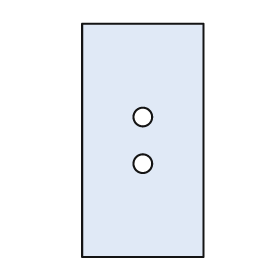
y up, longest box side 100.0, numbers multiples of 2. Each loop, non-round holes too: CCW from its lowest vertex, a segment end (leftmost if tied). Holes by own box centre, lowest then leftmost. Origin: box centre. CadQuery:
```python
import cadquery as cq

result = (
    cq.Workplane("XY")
    .moveTo(-26.0, -50.0)
    .lineTo(26.0, -50.0)
    .lineTo(26.0, 50.0)
    .lineTo(-26.0, 50.0)
    .close()
    .moveTo(0.0, -10.0)
    .circle(4.0)
    .moveTo(0.0, 10.0)
    .circle(4.0)
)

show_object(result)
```